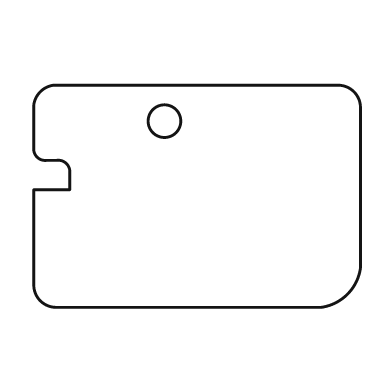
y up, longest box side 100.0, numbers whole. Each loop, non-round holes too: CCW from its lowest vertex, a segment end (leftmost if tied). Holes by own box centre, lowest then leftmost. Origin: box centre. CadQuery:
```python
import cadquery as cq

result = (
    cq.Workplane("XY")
    .moveTo(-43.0, -34.0)
    .lineTo(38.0, -34.0)
    .threePointArc((46.0, -30.0), (50.0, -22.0))
    .lineTo(50.0, 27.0)
    .threePointArc((48.0, 32.0), (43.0, 34.0))
    .lineTo(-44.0, 34.0)
    .threePointArc((-48.0, 32.0), (-50.0, 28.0))
    .lineTo(-50.0, 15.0)
    .threePointArc((-49.0, 12.0), (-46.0, 11.0))
    .lineTo(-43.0, 11.0)
    .threePointArc((-40.0, 10.0), (-39.0, 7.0))
    .lineTo(-39.0, 2.0)
    .lineTo(-50.0, 2.0)
    .lineTo(-50.0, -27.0)
    .threePointArc((-48.0, -32.0), (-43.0, -34.0))
    .close()
    .moveTo(-10.0, 23.0)
    .circle(5.0)
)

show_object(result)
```